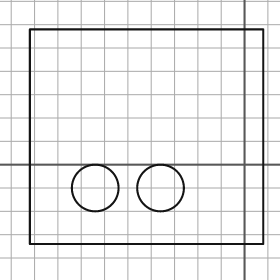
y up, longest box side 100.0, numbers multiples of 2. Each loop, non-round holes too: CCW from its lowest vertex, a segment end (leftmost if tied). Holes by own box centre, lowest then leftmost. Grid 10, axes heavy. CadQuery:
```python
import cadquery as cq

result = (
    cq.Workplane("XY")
    .moveTo(-92.0, -34.0)
    .lineTo(8.0, -34.0)
    .lineTo(8.0, 58.0)
    .lineTo(-92.0, 58.0)
    .close()
    .moveTo(-64.0, -10.0)
    .circle(10.0)
    .moveTo(-36.0, -10.0)
    .circle(10.0)
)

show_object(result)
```